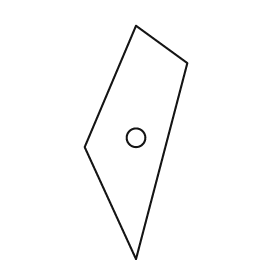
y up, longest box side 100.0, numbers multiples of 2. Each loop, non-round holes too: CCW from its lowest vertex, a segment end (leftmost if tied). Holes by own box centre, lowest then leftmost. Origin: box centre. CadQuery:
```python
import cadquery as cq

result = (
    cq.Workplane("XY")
    .moveTo(0.0, -50.0)
    .lineTo(22.0, 34.0)
    .lineTo(0.0, 50.0)
    .lineTo(-22.0, -2.0)
    .close()
    .moveTo(0.0, 2.0)
    .circle(4.0)
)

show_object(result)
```